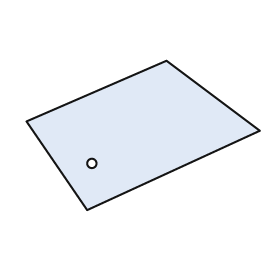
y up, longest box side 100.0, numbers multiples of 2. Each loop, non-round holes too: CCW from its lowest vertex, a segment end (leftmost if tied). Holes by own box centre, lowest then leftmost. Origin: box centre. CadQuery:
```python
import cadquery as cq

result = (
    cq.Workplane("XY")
    .moveTo(-24.0, -32.0)
    .lineTo(50.0, 2.0)
    .lineTo(10.0, 32.0)
    .lineTo(-50.0, 6.0)
    .close()
    .moveTo(-22.0, -12.0)
    .circle(2.0)
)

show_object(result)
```